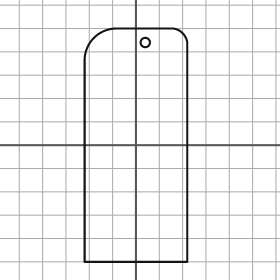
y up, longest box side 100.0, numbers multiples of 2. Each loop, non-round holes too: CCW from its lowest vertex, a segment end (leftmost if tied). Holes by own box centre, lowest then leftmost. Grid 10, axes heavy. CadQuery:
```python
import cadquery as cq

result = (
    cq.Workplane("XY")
    .moveTo(-22.0, -50.0)
    .lineTo(22.0, -50.0)
    .lineTo(22.0, 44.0)
    .threePointArc((20.0, 48.0), (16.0, 50.0))
    .lineTo(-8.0, 50.0)
    .threePointArc((-18.0, 46.0), (-22.0, 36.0))
    .close()
    .moveTo(4.0, 44.0)
    .circle(2.0)
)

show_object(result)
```